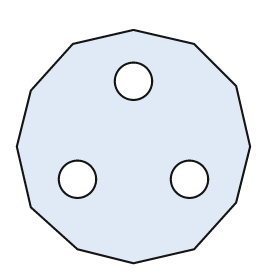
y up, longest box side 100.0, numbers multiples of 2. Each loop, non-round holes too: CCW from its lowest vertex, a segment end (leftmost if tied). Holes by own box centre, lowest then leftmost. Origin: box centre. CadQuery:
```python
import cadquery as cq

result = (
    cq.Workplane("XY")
    .moveTo(0.0, -50.0)
    .lineTo(26.0, -44.0)
    .lineTo(44.0, -24.0)
    .lineTo(50.0, 0.0)
    .lineTo(44.0, 26.0)
    .lineTo(26.0, 44.0)
    .lineTo(0.0, 50.0)
    .lineTo(-26.0, 44.0)
    .lineTo(-44.0, 24.0)
    .lineTo(-50.0, 0.0)
    .lineTo(-44.0, -26.0)
    .lineTo(-24.0, -44.0)
    .close()
    .moveTo(-24.0, -14.0)
    .circle(8.0)
    .moveTo(24.0, -14.0)
    .circle(8.0)
    .moveTo(0.0, 28.0)
    .circle(8.0)
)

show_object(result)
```